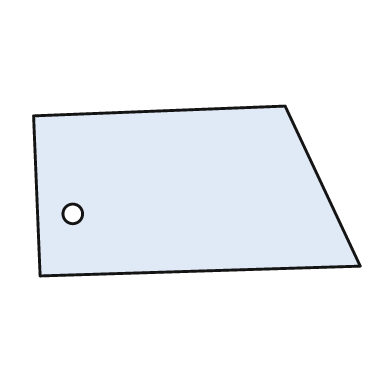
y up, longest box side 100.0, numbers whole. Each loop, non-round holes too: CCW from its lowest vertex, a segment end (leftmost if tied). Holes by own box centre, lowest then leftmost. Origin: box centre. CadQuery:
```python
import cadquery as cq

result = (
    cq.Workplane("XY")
    .moveTo(-48.0, -26.0)
    .lineTo(50.0, -23.0)
    .lineTo(27.0, 26.0)
    .lineTo(-50.0, 23.0)
    .close()
    .moveTo(-38.0, -7.0)
    .circle(3.0)
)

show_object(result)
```